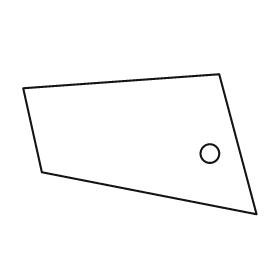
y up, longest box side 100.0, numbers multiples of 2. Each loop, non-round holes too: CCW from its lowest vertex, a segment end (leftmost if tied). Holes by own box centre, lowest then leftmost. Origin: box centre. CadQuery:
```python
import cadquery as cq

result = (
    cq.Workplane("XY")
    .moveTo(50.0, -30.0)
    .lineTo(34.0, 30.0)
    .lineTo(-50.0, 24.0)
    .lineTo(-42.0, -12.0)
    .close()
    .moveTo(30.0, -4.0)
    .circle(4.0)
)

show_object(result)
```